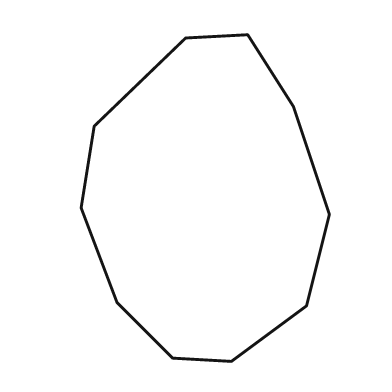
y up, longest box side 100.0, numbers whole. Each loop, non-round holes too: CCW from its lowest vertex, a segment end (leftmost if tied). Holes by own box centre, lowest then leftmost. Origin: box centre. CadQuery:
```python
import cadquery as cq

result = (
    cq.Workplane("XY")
    .moveTo(8.0, -50.0)
    .lineTo(31.0, -33.0)
    .lineTo(38.0, -5.0)
    .lineTo(27.0, 28.0)
    .lineTo(13.0, 50.0)
    .lineTo(-6.0, 49.0)
    .lineTo(-34.0, 22.0)
    .lineTo(-38.0, -3.0)
    .lineTo(-27.0, -32.0)
    .lineTo(-10.0, -49.0)
    .close()
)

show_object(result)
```